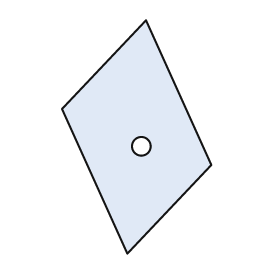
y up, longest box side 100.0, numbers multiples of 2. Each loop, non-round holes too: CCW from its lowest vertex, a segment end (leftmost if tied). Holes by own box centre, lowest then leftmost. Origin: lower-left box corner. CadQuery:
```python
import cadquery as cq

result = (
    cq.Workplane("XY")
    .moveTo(28.0, 0.0)
    .lineTo(64.0, 38.0)
    .lineTo(36.0, 100.0)
    .lineTo(0.0, 62.0)
    .close()
    .moveTo(34.0, 46.0)
    .circle(4.0)
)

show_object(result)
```